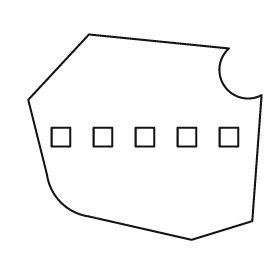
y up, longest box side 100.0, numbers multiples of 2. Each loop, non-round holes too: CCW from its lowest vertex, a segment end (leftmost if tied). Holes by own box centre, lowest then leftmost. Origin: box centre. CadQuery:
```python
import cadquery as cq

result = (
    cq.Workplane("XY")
    .moveTo(20.0, -44.0)
    .lineTo(46.0, -36.0)
    .lineTo(50.0, 18.0)
    .threePointArc((34.0, 22.0), (36.0, 38.0))
    .lineTo(-24.0, 44.0)
    .lineTo(-50.0, 16.0)
    .lineTo(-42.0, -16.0)
    .threePointArc((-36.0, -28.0), (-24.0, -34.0))
    .close()
    .moveTo(-40.0, -4.0)
    .lineTo(-32.0, -4.0)
    .lineTo(-32.0, 4.0)
    .lineTo(-40.0, 4.0)
    .close()
    .moveTo(-22.0, -4.0)
    .lineTo(-14.0, -4.0)
    .lineTo(-14.0, 4.0)
    .lineTo(-22.0, 4.0)
    .close()
    .moveTo(-4.0, -4.0)
    .lineTo(4.0, -4.0)
    .lineTo(4.0, 4.0)
    .lineTo(-4.0, 4.0)
    .close()
    .moveTo(14.0, -4.0)
    .lineTo(22.0, -4.0)
    .lineTo(22.0, 4.0)
    .lineTo(14.0, 4.0)
    .close()
    .moveTo(32.0, -4.0)
    .lineTo(40.0, -4.0)
    .lineTo(40.0, 4.0)
    .lineTo(32.0, 4.0)
    .close()
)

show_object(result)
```